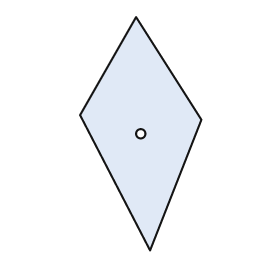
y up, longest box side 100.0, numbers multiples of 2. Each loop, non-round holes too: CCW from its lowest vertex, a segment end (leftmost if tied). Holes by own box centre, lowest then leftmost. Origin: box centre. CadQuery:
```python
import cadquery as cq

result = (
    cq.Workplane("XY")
    .moveTo(4.0, -50.0)
    .lineTo(26.0, 6.0)
    .lineTo(-2.0, 50.0)
    .lineTo(-26.0, 8.0)
    .close()
    .moveTo(0.0, 0.0)
    .circle(2.0)
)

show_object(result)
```